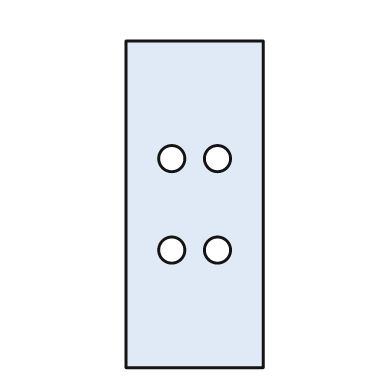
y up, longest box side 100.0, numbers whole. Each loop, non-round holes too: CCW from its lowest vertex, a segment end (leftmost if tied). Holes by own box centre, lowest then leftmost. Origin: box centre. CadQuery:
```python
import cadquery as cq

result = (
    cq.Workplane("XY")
    .moveTo(-21.0, -50.0)
    .lineTo(21.0, -50.0)
    .lineTo(21.0, 50.0)
    .lineTo(-21.0, 50.0)
    .close()
    .moveTo(-7.0, -14.0)
    .circle(4.0)
    .moveTo(7.0, -14.0)
    .circle(4.0)
    .moveTo(-7.0, 14.0)
    .circle(4.0)
    .moveTo(7.0, 14.0)
    .circle(4.0)
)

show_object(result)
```